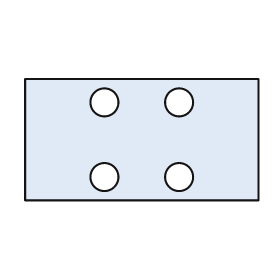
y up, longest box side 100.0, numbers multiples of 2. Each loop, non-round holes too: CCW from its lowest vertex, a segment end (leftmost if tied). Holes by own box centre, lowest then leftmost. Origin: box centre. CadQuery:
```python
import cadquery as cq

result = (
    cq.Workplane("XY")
    .moveTo(-50.0, -26.0)
    .lineTo(50.0, -26.0)
    .lineTo(50.0, 26.0)
    .lineTo(-50.0, 26.0)
    .close()
    .moveTo(-16.0, -16.0)
    .circle(6.0)
    .moveTo(16.0, -16.0)
    .circle(6.0)
    .moveTo(-16.0, 16.0)
    .circle(6.0)
    .moveTo(16.0, 16.0)
    .circle(6.0)
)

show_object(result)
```